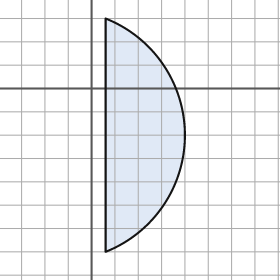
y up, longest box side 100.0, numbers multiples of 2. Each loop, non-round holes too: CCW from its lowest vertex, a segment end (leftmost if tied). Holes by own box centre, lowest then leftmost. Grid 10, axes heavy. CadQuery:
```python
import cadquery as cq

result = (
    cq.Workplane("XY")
    .moveTo(6.0, -70.0)
    .threePointArc((40.0, -20.0), (6.0, 30.0))
    .close()
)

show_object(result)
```